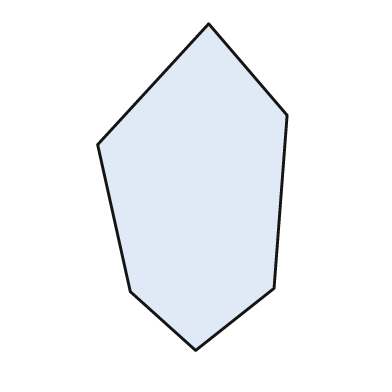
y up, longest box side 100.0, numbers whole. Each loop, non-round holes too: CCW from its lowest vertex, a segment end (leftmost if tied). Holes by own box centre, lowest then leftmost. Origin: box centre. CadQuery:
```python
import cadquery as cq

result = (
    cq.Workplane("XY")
    .moveTo(1.0, -50.0)
    .lineTo(25.0, -31.0)
    .lineTo(29.0, 22.0)
    .lineTo(5.0, 50.0)
    .lineTo(-29.0, 13.0)
    .lineTo(-19.0, -32.0)
    .close()
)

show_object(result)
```